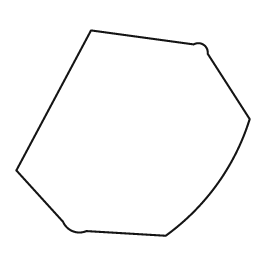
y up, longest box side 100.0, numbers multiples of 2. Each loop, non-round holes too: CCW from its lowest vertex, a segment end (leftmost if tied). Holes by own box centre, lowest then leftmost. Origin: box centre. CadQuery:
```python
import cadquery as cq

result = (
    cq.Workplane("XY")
    .moveTo(14.0, -44.0)
    .threePointArc((36.0, -22.0), (50.0, 6.0))
    .lineTo(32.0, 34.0)
    .threePointArc((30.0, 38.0), (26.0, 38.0))
    .lineTo(-18.0, 44.0)
    .lineTo(-50.0, -16.0)
    .lineTo(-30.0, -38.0)
    .threePointArc((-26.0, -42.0), (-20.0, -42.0))
    .close()
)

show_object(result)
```